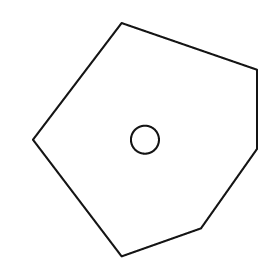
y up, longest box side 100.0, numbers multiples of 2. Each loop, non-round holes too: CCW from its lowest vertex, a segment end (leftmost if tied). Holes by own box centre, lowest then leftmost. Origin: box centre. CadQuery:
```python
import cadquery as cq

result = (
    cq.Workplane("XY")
    .moveTo(-10.0, -50.0)
    .lineTo(24.0, -38.0)
    .lineTo(48.0, -4.0)
    .lineTo(48.0, 30.0)
    .lineTo(-10.0, 50.0)
    .lineTo(-48.0, 0.0)
    .close()
    .moveTo(0.0, 0.0)
    .circle(6.0)
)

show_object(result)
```